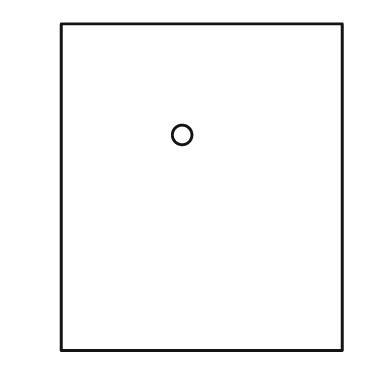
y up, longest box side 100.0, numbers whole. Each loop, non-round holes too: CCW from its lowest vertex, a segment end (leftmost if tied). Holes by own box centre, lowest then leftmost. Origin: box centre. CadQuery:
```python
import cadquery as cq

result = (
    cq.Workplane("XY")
    .moveTo(-43.0, -50.0)
    .lineTo(43.0, -50.0)
    .lineTo(43.0, 50.0)
    .lineTo(-43.0, 50.0)
    .close()
    .moveTo(-6.0, 16.0)
    .circle(3.0)
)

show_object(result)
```